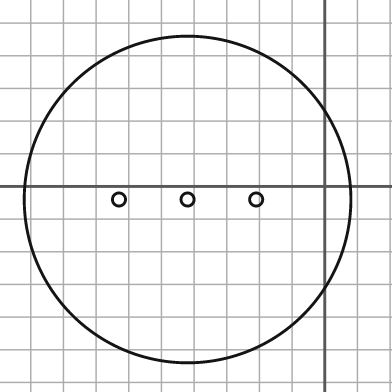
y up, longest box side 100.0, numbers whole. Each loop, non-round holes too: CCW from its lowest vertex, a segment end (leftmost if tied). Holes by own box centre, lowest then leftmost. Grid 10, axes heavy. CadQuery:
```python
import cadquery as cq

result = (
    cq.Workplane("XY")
    .moveTo(-42.0, -4.0)
    .circle(50.0)
    .moveTo(-63.0, -4.0)
    .circle(2.0)
    .moveTo(-42.0, -4.0)
    .circle(2.0)
    .moveTo(-21.0, -4.0)
    .circle(2.0)
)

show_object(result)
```